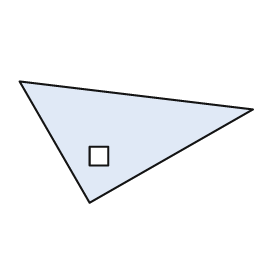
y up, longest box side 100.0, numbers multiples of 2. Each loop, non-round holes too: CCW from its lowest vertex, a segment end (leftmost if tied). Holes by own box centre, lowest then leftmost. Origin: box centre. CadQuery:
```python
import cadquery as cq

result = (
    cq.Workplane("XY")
    .moveTo(-20.0, -26.0)
    .lineTo(50.0, 14.0)
    .lineTo(-50.0, 26.0)
    .close()
    .moveTo(-20.0, -10.0)
    .lineTo(-12.0, -10.0)
    .lineTo(-12.0, -2.0)
    .lineTo(-20.0, -2.0)
    .close()
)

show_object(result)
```